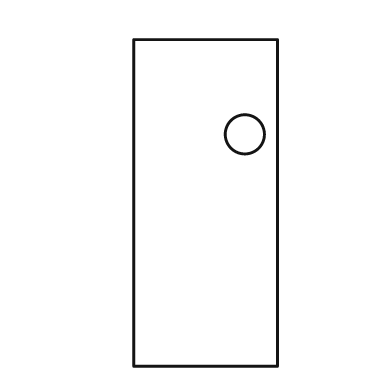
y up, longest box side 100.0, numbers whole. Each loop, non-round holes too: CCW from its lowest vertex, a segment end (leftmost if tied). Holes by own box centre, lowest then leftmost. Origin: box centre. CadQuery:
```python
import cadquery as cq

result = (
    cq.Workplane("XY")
    .moveTo(-22.0, -50.0)
    .lineTo(22.0, -50.0)
    .lineTo(22.0, 50.0)
    .lineTo(-22.0, 50.0)
    .close()
    .moveTo(12.0, 21.0)
    .circle(6.0)
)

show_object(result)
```